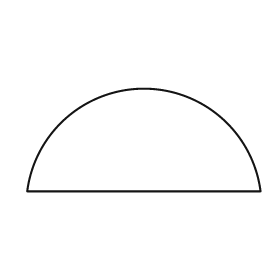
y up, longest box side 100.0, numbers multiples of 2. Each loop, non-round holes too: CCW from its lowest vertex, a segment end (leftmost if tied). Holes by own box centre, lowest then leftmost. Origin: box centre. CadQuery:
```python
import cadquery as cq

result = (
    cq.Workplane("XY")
    .moveTo(-50.0, -22.0)
    .lineTo(50.0, -22.0)
    .threePointArc((0.0, 22.0), (-50.0, -22.0))
    .close()
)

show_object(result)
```